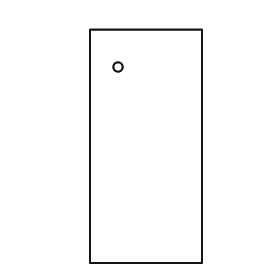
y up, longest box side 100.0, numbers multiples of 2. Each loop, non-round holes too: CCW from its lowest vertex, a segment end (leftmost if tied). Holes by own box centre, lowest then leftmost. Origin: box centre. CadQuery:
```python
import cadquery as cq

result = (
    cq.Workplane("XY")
    .moveTo(-24.0, -50.0)
    .lineTo(24.0, -50.0)
    .lineTo(24.0, 50.0)
    .lineTo(-24.0, 50.0)
    .close()
    .moveTo(-12.0, 34.0)
    .circle(2.0)
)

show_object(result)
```